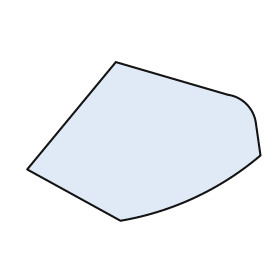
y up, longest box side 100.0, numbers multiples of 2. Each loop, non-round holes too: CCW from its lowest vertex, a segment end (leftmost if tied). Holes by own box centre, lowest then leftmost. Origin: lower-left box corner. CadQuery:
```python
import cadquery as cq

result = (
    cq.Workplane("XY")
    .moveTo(40.0, 0.0)
    .threePointArc((72.0, 10.0), (100.0, 28.0))
    .lineTo(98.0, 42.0)
    .threePointArc((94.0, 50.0), (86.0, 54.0))
    .lineTo(38.0, 68.0)
    .lineTo(0.0, 22.0)
    .close()
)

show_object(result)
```